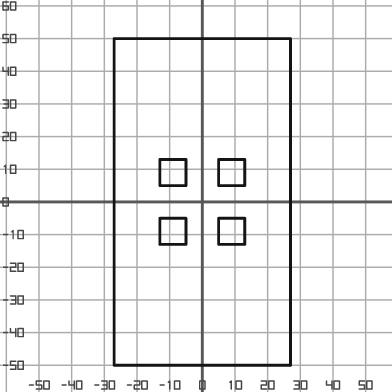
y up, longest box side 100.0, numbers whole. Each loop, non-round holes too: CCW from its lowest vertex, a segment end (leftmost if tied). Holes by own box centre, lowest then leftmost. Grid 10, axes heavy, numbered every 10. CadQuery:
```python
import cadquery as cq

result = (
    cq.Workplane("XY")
    .moveTo(-27.0, -50.0)
    .lineTo(27.0, -50.0)
    .lineTo(27.0, 50.0)
    .lineTo(-27.0, 50.0)
    .close()
    .moveTo(-13.0, -13.0)
    .lineTo(-5.0, -13.0)
    .lineTo(-5.0, -5.0)
    .lineTo(-13.0, -5.0)
    .close()
    .moveTo(5.0, -13.0)
    .lineTo(13.0, -13.0)
    .lineTo(13.0, -5.0)
    .lineTo(5.0, -5.0)
    .close()
    .moveTo(-13.0, 5.0)
    .lineTo(-5.0, 5.0)
    .lineTo(-5.0, 13.0)
    .lineTo(-13.0, 13.0)
    .close()
    .moveTo(5.0, 5.0)
    .lineTo(13.0, 5.0)
    .lineTo(13.0, 13.0)
    .lineTo(5.0, 13.0)
    .close()
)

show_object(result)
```